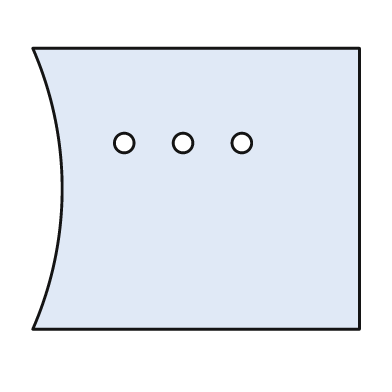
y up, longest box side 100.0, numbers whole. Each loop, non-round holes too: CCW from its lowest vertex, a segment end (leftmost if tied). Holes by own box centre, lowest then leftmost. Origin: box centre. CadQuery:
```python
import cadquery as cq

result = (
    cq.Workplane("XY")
    .moveTo(-50.0, -43.0)
    .lineTo(50.0, -43.0)
    .lineTo(50.0, 43.0)
    .lineTo(-50.0, 43.0)
    .threePointArc((-41.0, 0.0), (-50.0, -43.0))
    .close()
    .moveTo(-22.0, 14.0)
    .circle(3.0)
    .moveTo(-4.0, 14.0)
    .circle(3.0)
    .moveTo(14.0, 14.0)
    .circle(3.0)
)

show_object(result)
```